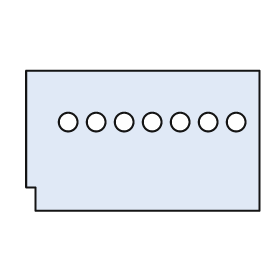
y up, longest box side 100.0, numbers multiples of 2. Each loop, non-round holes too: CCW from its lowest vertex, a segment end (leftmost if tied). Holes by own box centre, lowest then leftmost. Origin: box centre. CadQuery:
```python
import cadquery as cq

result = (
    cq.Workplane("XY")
    .moveTo(-46.0, -30.0)
    .lineTo(50.0, -30.0)
    .lineTo(50.0, 30.0)
    .lineTo(-50.0, 30.0)
    .lineTo(-50.0, -20.0)
    .lineTo(-46.0, -20.0)
    .close()
    .moveTo(-32.0, 8.0)
    .circle(4.0)
    .moveTo(-20.0, 8.0)
    .circle(4.0)
    .moveTo(-8.0, 8.0)
    .circle(4.0)
    .moveTo(4.0, 8.0)
    .circle(4.0)
    .moveTo(16.0, 8.0)
    .circle(4.0)
    .moveTo(28.0, 8.0)
    .circle(4.0)
    .moveTo(40.0, 8.0)
    .circle(4.0)
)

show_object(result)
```